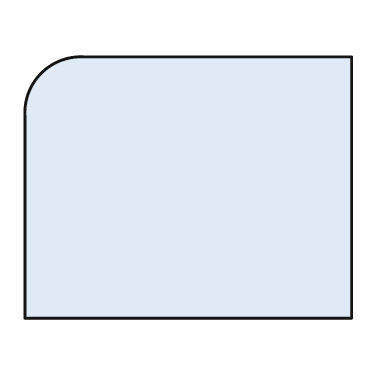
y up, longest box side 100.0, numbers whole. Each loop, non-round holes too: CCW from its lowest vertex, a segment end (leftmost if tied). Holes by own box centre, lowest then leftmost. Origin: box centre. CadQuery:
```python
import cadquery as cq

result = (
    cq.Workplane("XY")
    .moveTo(-50.0, -40.0)
    .lineTo(50.0, -40.0)
    .lineTo(50.0, 40.0)
    .lineTo(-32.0, 40.0)
    .threePointArc((-45.0, 35.0), (-50.0, 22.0))
    .close()
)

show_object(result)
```